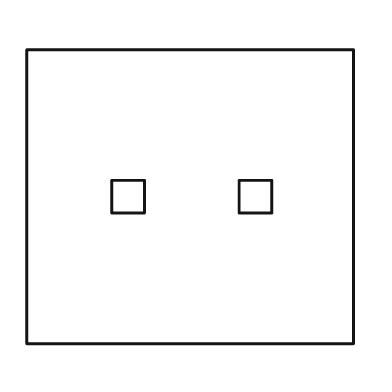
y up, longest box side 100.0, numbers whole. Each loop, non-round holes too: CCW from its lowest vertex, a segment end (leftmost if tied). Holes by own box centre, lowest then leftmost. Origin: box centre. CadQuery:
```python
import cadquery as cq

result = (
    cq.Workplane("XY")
    .moveTo(-50.0, -45.0)
    .lineTo(50.0, -45.0)
    .lineTo(50.0, 45.0)
    .lineTo(-50.0, 45.0)
    .close()
    .moveTo(-24.0, -5.0)
    .lineTo(-14.0, -5.0)
    .lineTo(-14.0, 5.0)
    .lineTo(-24.0, 5.0)
    .close()
    .moveTo(15.0, -5.0)
    .lineTo(25.0, -5.0)
    .lineTo(25.0, 5.0)
    .lineTo(15.0, 5.0)
    .close()
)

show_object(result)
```